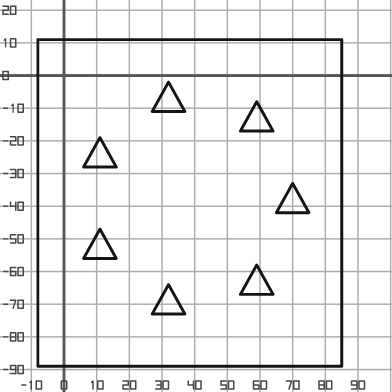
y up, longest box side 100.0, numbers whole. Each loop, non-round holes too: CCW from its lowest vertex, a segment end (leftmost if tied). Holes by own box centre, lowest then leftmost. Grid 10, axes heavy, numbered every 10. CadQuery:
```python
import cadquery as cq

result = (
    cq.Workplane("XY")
    .moveTo(-8.0, -89.0)
    .lineTo(85.0, -89.0)
    .lineTo(85.0, 11.0)
    .lineTo(-8.0, 11.0)
    .close()
    .moveTo(27.0, -73.0)
    .lineTo(37.0, -73.0)
    .lineTo(32.0, -64.0)
    .close()
    .moveTo(54.0, -67.0)
    .lineTo(64.0, -67.0)
    .lineTo(59.0, -58.0)
    .close()
    .moveTo(6.0, -56.0)
    .lineTo(16.0, -56.0)
    .lineTo(11.0, -47.0)
    .close()
    .moveTo(65.0, -42.0)
    .lineTo(75.0, -42.0)
    .lineTo(70.0, -33.0)
    .close()
    .moveTo(6.0, -28.0)
    .lineTo(16.0, -28.0)
    .lineTo(11.0, -19.0)
    .close()
    .moveTo(54.0, -17.0)
    .lineTo(64.0, -17.0)
    .lineTo(59.0, -8.0)
    .close()
    .moveTo(27.0, -11.0)
    .lineTo(37.0, -11.0)
    .lineTo(32.0, -2.0)
    .close()
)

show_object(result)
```